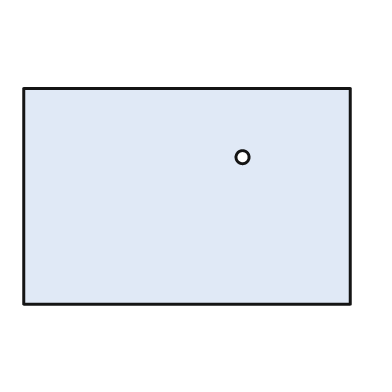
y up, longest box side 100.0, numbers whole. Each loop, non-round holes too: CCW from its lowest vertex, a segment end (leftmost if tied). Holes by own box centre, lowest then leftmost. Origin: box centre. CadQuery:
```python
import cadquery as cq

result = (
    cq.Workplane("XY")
    .moveTo(-50.0, -33.0)
    .lineTo(50.0, -33.0)
    .lineTo(50.0, 33.0)
    .lineTo(-50.0, 33.0)
    .close()
    .moveTo(17.0, 12.0)
    .circle(2.0)
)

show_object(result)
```